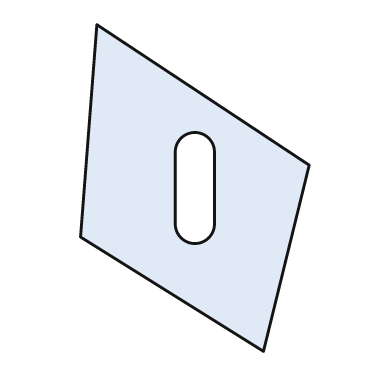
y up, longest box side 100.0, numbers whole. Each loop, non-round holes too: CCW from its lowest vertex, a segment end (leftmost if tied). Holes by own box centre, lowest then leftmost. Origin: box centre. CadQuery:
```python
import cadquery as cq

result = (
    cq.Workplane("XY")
    .moveTo(21.0, -50.0)
    .lineTo(35.0, 7.0)
    .lineTo(-30.0, 50.0)
    .lineTo(-35.0, -15.0)
    .close()
    .moveTo(-6.0, -11.0)
    .threePointArc((0.0, -17.0), (6.0, -11.0))
    .lineTo(6.0, 11.0)
    .threePointArc((0.0, 17.0), (-6.0, 11.0))
    .close()
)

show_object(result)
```